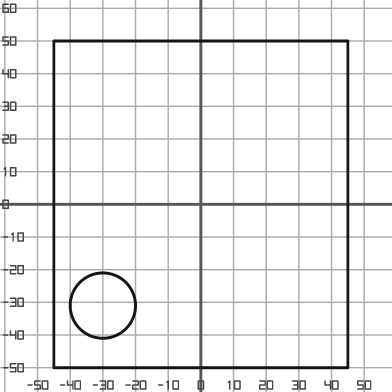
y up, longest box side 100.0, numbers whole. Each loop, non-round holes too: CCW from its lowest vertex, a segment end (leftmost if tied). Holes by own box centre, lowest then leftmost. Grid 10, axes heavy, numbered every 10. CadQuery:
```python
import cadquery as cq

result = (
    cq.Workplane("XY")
    .moveTo(-45.0, -50.0)
    .lineTo(45.0, -50.0)
    .lineTo(45.0, 50.0)
    .lineTo(-45.0, 50.0)
    .close()
    .moveTo(-30.0, -31.0)
    .circle(10.0)
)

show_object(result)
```